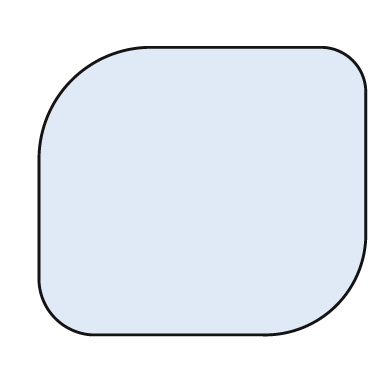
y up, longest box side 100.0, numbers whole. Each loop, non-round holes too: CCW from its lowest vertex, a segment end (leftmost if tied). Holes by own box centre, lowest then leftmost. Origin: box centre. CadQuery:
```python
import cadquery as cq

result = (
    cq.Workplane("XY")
    .moveTo(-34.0, -44.0)
    .lineTo(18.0, -44.0)
    .threePointArc((41.0, -35.0), (50.0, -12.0))
    .lineTo(50.0, 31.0)
    .threePointArc((46.0, 40.0), (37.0, 44.0))
    .lineTo(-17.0, 44.0)
    .threePointArc((-40.0, 34.0), (-50.0, 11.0))
    .lineTo(-50.0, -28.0)
    .threePointArc((-45.0, -39.0), (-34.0, -44.0))
    .close()
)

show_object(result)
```